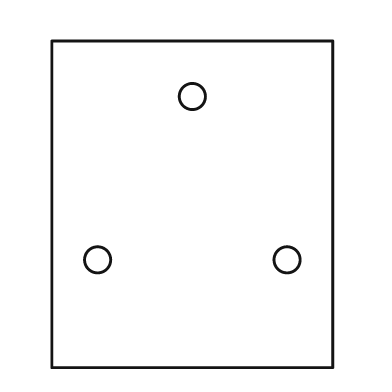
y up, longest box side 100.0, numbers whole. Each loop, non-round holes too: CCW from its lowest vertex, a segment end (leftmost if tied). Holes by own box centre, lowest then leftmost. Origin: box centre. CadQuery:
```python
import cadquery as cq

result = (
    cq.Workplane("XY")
    .moveTo(-43.0, -50.0)
    .lineTo(43.0, -50.0)
    .lineTo(43.0, 50.0)
    .lineTo(-43.0, 50.0)
    .close()
    .moveTo(-29.0, -17.0)
    .circle(4.0)
    .moveTo(29.0, -17.0)
    .circle(4.0)
    .moveTo(0.0, 33.0)
    .circle(4.0)
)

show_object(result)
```